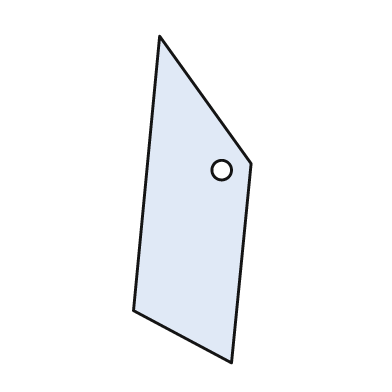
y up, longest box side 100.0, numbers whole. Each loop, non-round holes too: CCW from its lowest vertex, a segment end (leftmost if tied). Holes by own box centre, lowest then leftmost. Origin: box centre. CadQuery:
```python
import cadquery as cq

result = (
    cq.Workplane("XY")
    .moveTo(12.0, -50.0)
    .lineTo(18.0, 11.0)
    .lineTo(-10.0, 50.0)
    .lineTo(-18.0, -34.0)
    .close()
    .moveTo(9.0, 9.0)
    .circle(3.0)
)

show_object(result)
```